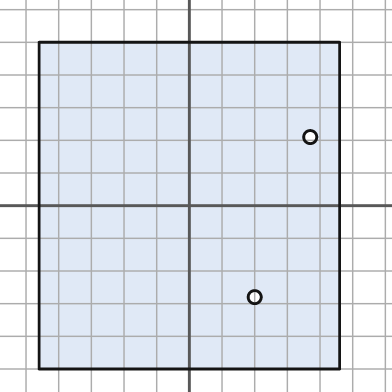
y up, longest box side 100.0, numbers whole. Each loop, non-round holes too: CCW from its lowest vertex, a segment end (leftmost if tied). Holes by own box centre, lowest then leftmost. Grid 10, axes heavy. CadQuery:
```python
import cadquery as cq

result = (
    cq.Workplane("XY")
    .moveTo(-46.0, -50.0)
    .lineTo(46.0, -50.0)
    .lineTo(46.0, 50.0)
    .lineTo(-46.0, 50.0)
    .close()
    .moveTo(20.0, -28.0)
    .circle(2.0)
    .moveTo(37.0, 21.0)
    .circle(2.0)
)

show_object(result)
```